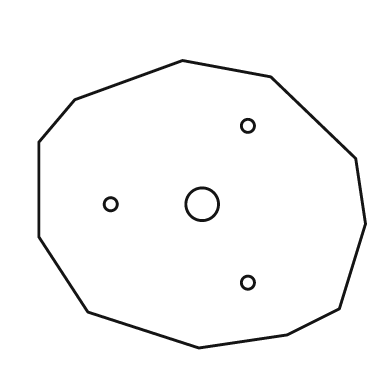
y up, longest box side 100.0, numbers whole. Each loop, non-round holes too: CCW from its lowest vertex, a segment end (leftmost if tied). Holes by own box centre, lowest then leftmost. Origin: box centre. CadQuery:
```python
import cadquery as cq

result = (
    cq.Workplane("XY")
    .moveTo(-1.0, -44.0)
    .lineTo(26.0, -40.0)
    .lineTo(42.0, -32.0)
    .lineTo(50.0, -6.0)
    .lineTo(47.0, 14.0)
    .lineTo(21.0, 39.0)
    .lineTo(-6.0, 44.0)
    .lineTo(-39.0, 32.0)
    .lineTo(-50.0, 19.0)
    .lineTo(-50.0, -10.0)
    .lineTo(-35.0, -33.0)
    .close()
    .moveTo(14.0, -24.0)
    .circle(2.0)
    .moveTo(-28.0, 0.0)
    .circle(2.0)
    .moveTo(0.0, 0.0)
    .circle(5.0)
    .moveTo(14.0, 24.0)
    .circle(2.0)
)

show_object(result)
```